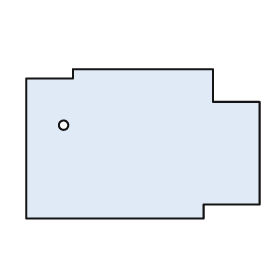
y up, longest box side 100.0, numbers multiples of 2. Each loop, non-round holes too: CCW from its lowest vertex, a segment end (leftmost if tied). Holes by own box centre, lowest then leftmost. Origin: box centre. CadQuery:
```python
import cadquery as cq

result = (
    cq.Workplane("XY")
    .moveTo(-50.0, -32.0)
    .lineTo(26.0, -32.0)
    .lineTo(26.0, -26.0)
    .lineTo(50.0, -26.0)
    .lineTo(50.0, 18.0)
    .lineTo(30.0, 18.0)
    .lineTo(30.0, 32.0)
    .lineTo(-30.0, 32.0)
    .lineTo(-30.0, 28.0)
    .lineTo(-50.0, 28.0)
    .close()
    .moveTo(-34.0, 8.0)
    .circle(2.0)
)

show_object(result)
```